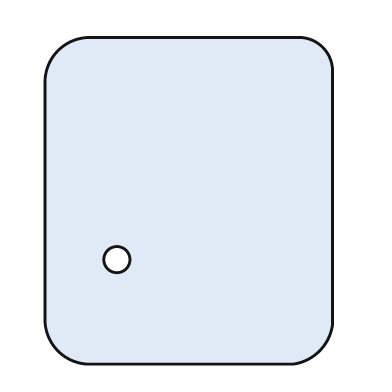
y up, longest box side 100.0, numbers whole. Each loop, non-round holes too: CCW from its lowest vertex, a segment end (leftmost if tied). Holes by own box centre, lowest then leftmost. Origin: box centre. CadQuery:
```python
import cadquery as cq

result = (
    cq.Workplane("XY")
    .moveTo(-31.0, -50.0)
    .lineTo(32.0, -50.0)
    .threePointArc((40.0, -46.0), (44.0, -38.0))
    .lineTo(44.0, 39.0)
    .threePointArc((41.0, 47.0), (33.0, 50.0))
    .lineTo(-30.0, 50.0)
    .threePointArc((-40.0, 46.0), (-44.0, 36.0))
    .lineTo(-44.0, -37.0)
    .threePointArc((-40.0, -46.0), (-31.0, -50.0))
    .close()
    .moveTo(-22.0, -18.0)
    .circle(4.0)
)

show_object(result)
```